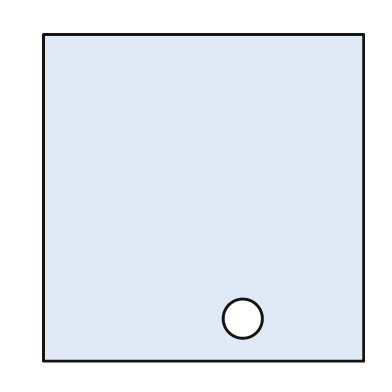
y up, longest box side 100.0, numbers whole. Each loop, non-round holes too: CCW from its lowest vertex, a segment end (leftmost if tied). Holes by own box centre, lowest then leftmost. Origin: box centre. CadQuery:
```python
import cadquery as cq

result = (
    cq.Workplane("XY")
    .moveTo(-49.0, -50.0)
    .lineTo(49.0, -50.0)
    .lineTo(49.0, 50.0)
    .lineTo(-49.0, 50.0)
    .close()
    .moveTo(12.0, -37.0)
    .circle(6.0)
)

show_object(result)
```